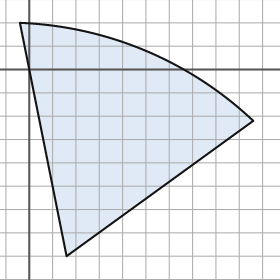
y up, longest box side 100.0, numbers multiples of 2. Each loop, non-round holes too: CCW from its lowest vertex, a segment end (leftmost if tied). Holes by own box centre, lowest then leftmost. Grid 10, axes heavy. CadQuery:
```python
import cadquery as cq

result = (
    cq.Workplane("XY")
    .moveTo(16.0, -80.0)
    .lineTo(96.0, -22.0)
    .threePointArc((50.0, 8.0), (-4.0, 20.0))
    .close()
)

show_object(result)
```